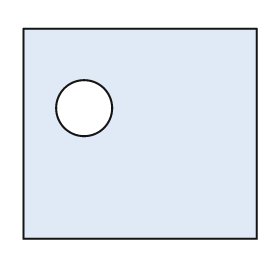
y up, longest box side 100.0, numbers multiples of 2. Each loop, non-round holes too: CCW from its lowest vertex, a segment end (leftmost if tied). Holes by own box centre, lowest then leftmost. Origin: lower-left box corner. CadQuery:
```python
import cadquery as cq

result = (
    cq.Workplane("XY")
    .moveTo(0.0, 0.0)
    .lineTo(100.0, 0.0)
    .lineTo(100.0, 90.0)
    .lineTo(0.0, 90.0)
    .close()
    .moveTo(26.0, 56.0)
    .circle(12.0)
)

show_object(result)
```